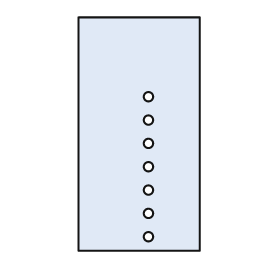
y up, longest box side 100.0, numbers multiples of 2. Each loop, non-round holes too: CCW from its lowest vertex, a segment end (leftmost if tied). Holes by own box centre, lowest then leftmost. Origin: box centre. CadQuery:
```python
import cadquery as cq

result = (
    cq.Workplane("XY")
    .moveTo(-26.0, -50.0)
    .lineTo(26.0, -50.0)
    .lineTo(26.0, 50.0)
    .lineTo(-26.0, 50.0)
    .close()
    .moveTo(4.0, -44.0)
    .circle(2.0)
    .moveTo(4.0, -34.0)
    .circle(2.0)
    .moveTo(4.0, -24.0)
    .circle(2.0)
    .moveTo(4.0, -14.0)
    .circle(2.0)
    .moveTo(4.0, -4.0)
    .circle(2.0)
    .moveTo(4.0, 6.0)
    .circle(2.0)
    .moveTo(4.0, 16.0)
    .circle(2.0)
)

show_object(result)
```